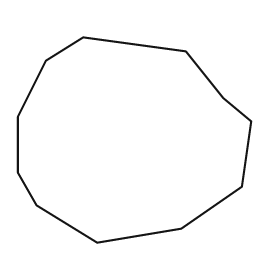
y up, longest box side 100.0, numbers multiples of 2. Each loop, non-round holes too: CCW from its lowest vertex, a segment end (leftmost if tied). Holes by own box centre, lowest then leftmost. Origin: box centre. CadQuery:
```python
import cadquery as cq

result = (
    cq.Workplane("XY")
    .moveTo(-16.0, -44.0)
    .lineTo(20.0, -38.0)
    .lineTo(46.0, -20.0)
    .lineTo(50.0, 8.0)
    .lineTo(38.0, 18.0)
    .lineTo(22.0, 38.0)
    .lineTo(-22.0, 44.0)
    .lineTo(-38.0, 34.0)
    .lineTo(-50.0, 10.0)
    .lineTo(-50.0, -14.0)
    .lineTo(-42.0, -28.0)
    .close()
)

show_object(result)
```